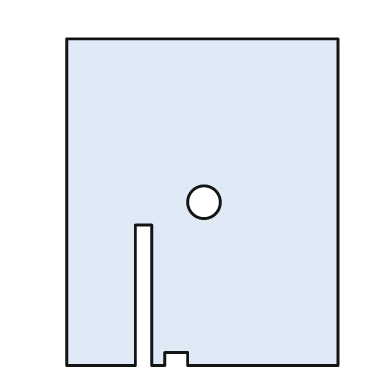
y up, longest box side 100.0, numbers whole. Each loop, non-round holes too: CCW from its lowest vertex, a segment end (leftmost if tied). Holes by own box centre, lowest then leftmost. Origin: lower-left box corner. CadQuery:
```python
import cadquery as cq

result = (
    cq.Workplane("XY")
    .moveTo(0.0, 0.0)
    .lineTo(21.0, 0.0)
    .lineTo(21.0, 43.0)
    .lineTo(26.0, 43.0)
    .lineTo(26.0, 0.0)
    .lineTo(30.0, 0.0)
    .lineTo(30.0, 4.0)
    .lineTo(37.0, 4.0)
    .lineTo(37.0, 0.0)
    .lineTo(83.0, 0.0)
    .lineTo(83.0, 100.0)
    .lineTo(0.0, 100.0)
    .close()
    .moveTo(42.0, 50.0)
    .circle(5.0)
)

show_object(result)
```